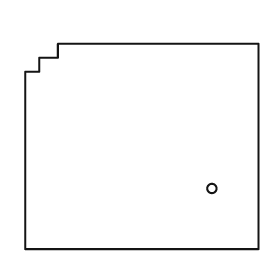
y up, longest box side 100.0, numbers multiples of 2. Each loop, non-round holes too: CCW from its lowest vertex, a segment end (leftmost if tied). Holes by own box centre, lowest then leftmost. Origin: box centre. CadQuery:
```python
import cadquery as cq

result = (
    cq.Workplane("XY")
    .moveTo(-50.0, -44.0)
    .lineTo(50.0, -44.0)
    .lineTo(50.0, 44.0)
    .lineTo(-36.0, 44.0)
    .lineTo(-36.0, 38.0)
    .lineTo(-44.0, 38.0)
    .lineTo(-44.0, 32.0)
    .lineTo(-50.0, 32.0)
    .close()
    .moveTo(30.0, -18.0)
    .circle(2.0)
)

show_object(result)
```